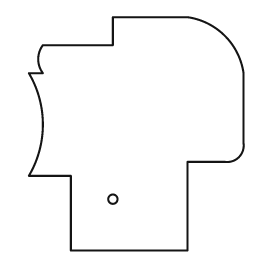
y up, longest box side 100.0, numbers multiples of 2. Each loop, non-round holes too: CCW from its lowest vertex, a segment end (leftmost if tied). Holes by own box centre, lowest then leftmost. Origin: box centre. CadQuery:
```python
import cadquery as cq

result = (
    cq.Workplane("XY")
    .moveTo(-28.0, -50.0)
    .lineTo(22.0, -50.0)
    .lineTo(22.0, -12.0)
    .lineTo(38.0, -12.0)
    .threePointArc((44.0, -10.0), (46.0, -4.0))
    .lineTo(46.0, 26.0)
    .threePointArc((38.0, 42.0), (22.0, 50.0))
    .lineTo(-10.0, 50.0)
    .lineTo(-10.0, 38.0)
    .lineTo(-40.0, 38.0)
    .threePointArc((-42.0, 32.0), (-40.0, 26.0))
    .lineTo(-46.0, 26.0)
    .threePointArc((-40.0, 4.0), (-46.0, -18.0))
    .lineTo(-28.0, -18.0)
    .close()
    .moveTo(-10.0, -28.0)
    .circle(2.0)
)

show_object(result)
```